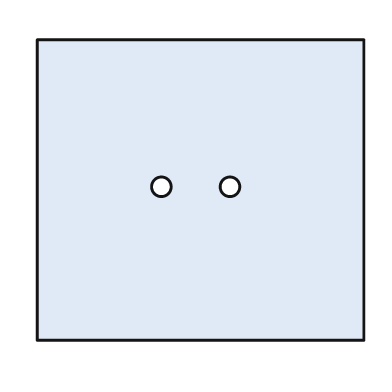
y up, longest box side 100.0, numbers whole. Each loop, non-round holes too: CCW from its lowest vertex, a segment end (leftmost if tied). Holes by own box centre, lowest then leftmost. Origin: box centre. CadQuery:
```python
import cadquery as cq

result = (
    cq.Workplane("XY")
    .moveTo(-50.0, -46.0)
    .lineTo(50.0, -46.0)
    .lineTo(50.0, 46.0)
    .lineTo(-50.0, 46.0)
    .close()
    .moveTo(-12.0, 1.0)
    .circle(3.0)
    .moveTo(9.0, 1.0)
    .circle(3.0)
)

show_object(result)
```